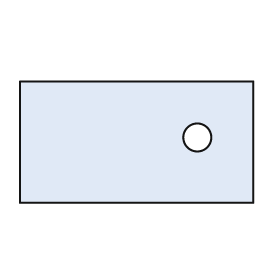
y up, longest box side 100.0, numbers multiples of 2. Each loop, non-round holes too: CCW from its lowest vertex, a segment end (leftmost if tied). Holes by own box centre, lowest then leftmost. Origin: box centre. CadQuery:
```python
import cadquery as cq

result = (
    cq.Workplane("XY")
    .moveTo(-50.0, -26.0)
    .lineTo(50.0, -26.0)
    .lineTo(50.0, 26.0)
    .lineTo(-50.0, 26.0)
    .close()
    .moveTo(26.0, 2.0)
    .circle(6.0)
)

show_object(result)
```